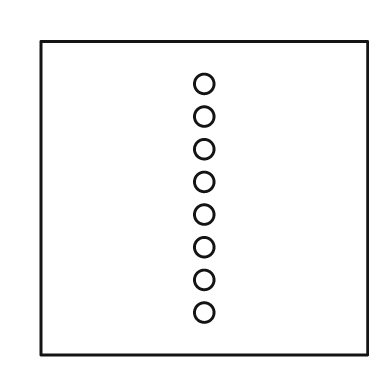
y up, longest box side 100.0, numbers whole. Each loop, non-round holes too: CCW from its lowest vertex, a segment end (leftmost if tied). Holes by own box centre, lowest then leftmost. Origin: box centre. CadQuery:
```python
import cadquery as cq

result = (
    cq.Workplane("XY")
    .moveTo(-50.0, -48.0)
    .lineTo(50.0, -48.0)
    .lineTo(50.0, 48.0)
    .lineTo(-50.0, 48.0)
    .close()
    .moveTo(0.0, -35.0)
    .circle(3.0)
    .moveTo(0.0, -25.0)
    .circle(3.0)
    .moveTo(0.0, -15.0)
    .circle(3.0)
    .moveTo(0.0, -5.0)
    .circle(3.0)
    .moveTo(0.0, 5.0)
    .circle(3.0)
    .moveTo(0.0, 15.0)
    .circle(3.0)
    .moveTo(0.0, 25.0)
    .circle(3.0)
    .moveTo(0.0, 35.0)
    .circle(3.0)
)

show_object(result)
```